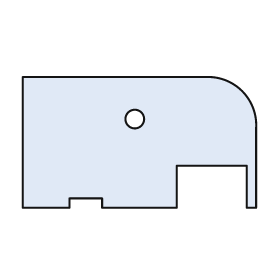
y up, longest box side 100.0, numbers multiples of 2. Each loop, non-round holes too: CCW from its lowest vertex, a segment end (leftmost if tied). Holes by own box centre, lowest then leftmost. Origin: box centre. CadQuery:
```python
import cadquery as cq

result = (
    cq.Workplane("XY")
    .moveTo(-50.0, -28.0)
    .lineTo(-30.0, -28.0)
    .lineTo(-30.0, -24.0)
    .lineTo(-16.0, -24.0)
    .lineTo(-16.0, -28.0)
    .lineTo(16.0, -28.0)
    .lineTo(16.0, -10.0)
    .lineTo(46.0, -10.0)
    .lineTo(46.0, -28.0)
    .lineTo(50.0, -28.0)
    .lineTo(50.0, 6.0)
    .threePointArc((44.0, 22.0), (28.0, 28.0))
    .lineTo(-50.0, 28.0)
    .close()
    .moveTo(-2.0, 10.0)
    .circle(4.0)
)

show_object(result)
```